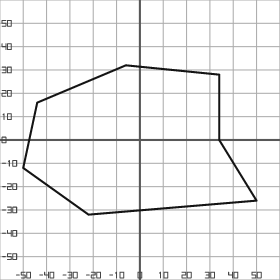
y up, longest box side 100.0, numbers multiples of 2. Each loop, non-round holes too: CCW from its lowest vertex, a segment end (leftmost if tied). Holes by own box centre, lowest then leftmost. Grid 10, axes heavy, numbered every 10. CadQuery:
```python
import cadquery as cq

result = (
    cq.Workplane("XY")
    .moveTo(-22.0, -32.0)
    .lineTo(50.0, -26.0)
    .lineTo(34.0, 0.0)
    .lineTo(34.0, 28.0)
    .lineTo(-6.0, 32.0)
    .lineTo(-44.0, 16.0)
    .lineTo(-50.0, -12.0)
    .close()
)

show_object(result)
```